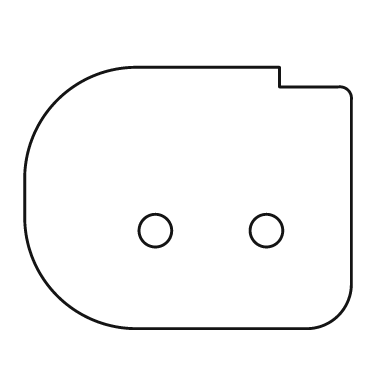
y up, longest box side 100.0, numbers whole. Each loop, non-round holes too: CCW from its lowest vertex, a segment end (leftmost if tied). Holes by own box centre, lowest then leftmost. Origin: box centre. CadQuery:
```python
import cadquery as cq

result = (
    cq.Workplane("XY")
    .moveTo(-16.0, -40.0)
    .lineTo(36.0, -40.0)
    .threePointArc((46.0, -36.0), (50.0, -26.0))
    .lineTo(50.0, 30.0)
    .threePointArc((49.0, 33.0), (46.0, 34.0))
    .lineTo(28.0, 34.0)
    .lineTo(28.0, 40.0)
    .lineTo(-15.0, 40.0)
    .threePointArc((-40.0, 30.0), (-50.0, 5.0))
    .lineTo(-50.0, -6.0)
    .threePointArc((-40.0, -30.0), (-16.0, -40.0))
    .close()
    .moveTo(-10.0, -10.0)
    .circle(5.0)
    .moveTo(24.0, -10.0)
    .circle(5.0)
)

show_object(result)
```